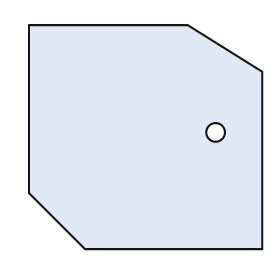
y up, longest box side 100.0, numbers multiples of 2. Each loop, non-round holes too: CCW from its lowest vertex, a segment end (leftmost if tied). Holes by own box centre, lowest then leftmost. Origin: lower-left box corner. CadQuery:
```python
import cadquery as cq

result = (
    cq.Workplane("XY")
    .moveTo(24.0, 0.0)
    .lineTo(100.0, 0.0)
    .lineTo(100.0, 76.0)
    .lineTo(68.0, 96.0)
    .lineTo(0.0, 96.0)
    .lineTo(0.0, 24.0)
    .close()
    .moveTo(80.0, 50.0)
    .circle(4.0)
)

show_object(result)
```